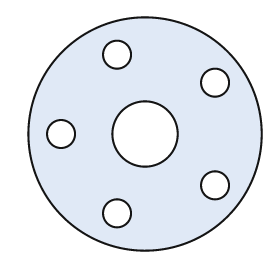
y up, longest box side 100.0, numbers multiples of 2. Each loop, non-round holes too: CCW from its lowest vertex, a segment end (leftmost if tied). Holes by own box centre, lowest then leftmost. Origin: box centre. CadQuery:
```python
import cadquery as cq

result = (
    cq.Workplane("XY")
    .moveTo(0.0, 0.0)
    .circle(50.0)
    .moveTo(-12.0, -34.0)
    .circle(6.0)
    .moveTo(30.0, -22.0)
    .circle(6.0)
    .moveTo(-36.0, 0.0)
    .circle(6.0)
    .moveTo(0.0, 0.0)
    .circle(14.0)
    .moveTo(30.0, 22.0)
    .circle(6.0)
    .moveTo(-12.0, 34.0)
    .circle(6.0)
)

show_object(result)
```